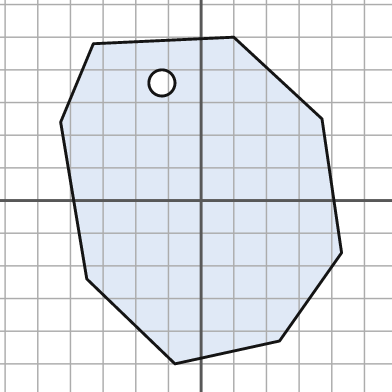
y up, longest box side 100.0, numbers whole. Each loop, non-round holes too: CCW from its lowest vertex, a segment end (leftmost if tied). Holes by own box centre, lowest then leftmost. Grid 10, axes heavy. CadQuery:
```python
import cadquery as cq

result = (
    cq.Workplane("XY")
    .moveTo(-8.0, -50.0)
    .lineTo(24.0, -43.0)
    .lineTo(43.0, -16.0)
    .lineTo(37.0, 25.0)
    .lineTo(10.0, 50.0)
    .lineTo(-33.0, 48.0)
    .lineTo(-43.0, 24.0)
    .lineTo(-35.0, -24.0)
    .close()
    .moveTo(-12.0, 36.0)
    .circle(4.0)
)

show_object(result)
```